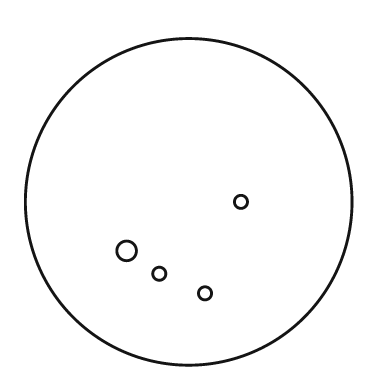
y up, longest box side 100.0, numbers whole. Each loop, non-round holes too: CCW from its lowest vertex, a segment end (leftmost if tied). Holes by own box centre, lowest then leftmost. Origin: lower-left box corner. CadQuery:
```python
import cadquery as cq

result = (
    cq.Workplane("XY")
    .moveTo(50.0, 50.0)
    .circle(50.0)
    .moveTo(55.0, 22.0)
    .circle(2.0)
    .moveTo(41.0, 28.0)
    .circle(2.0)
    .moveTo(31.0, 35.0)
    .circle(3.0)
    .moveTo(66.0, 50.0)
    .circle(2.0)
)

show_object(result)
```